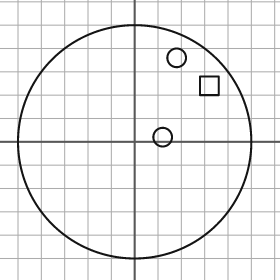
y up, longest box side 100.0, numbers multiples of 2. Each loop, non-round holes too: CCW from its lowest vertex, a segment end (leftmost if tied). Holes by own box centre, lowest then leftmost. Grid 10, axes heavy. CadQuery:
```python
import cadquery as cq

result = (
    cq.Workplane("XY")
    .moveTo(0.0, 0.0)
    .circle(50.0)
    .moveTo(12.0, 2.0)
    .circle(4.0)
    .moveTo(28.0, 20.0)
    .lineTo(36.0, 20.0)
    .lineTo(36.0, 28.0)
    .lineTo(28.0, 28.0)
    .close()
    .moveTo(18.0, 36.0)
    .circle(4.0)
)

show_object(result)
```